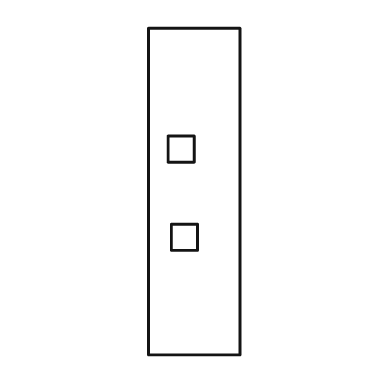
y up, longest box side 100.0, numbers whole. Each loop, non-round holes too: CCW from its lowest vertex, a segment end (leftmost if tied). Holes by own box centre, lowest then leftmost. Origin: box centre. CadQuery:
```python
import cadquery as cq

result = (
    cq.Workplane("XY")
    .moveTo(-14.0, -50.0)
    .lineTo(14.0, -50.0)
    .lineTo(14.0, 50.0)
    .lineTo(-14.0, 50.0)
    .close()
    .moveTo(-7.0, -18.0)
    .lineTo(1.0, -18.0)
    .lineTo(1.0, -10.0)
    .lineTo(-7.0, -10.0)
    .close()
    .moveTo(-8.0, 9.0)
    .lineTo(0.0, 9.0)
    .lineTo(0.0, 17.0)
    .lineTo(-8.0, 17.0)
    .close()
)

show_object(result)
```